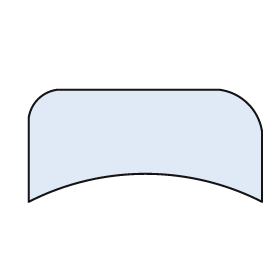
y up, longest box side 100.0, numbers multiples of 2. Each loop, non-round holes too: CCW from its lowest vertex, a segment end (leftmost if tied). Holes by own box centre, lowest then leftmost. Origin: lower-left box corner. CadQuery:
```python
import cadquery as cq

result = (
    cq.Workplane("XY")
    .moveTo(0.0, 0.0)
    .threePointArc((50.0, 12.0), (100.0, 0.0))
    .lineTo(100.0, 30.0)
    .threePointArc((94.0, 42.0), (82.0, 48.0))
    .lineTo(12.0, 48.0)
    .threePointArc((4.0, 44.0), (0.0, 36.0))
    .close()
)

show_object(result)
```